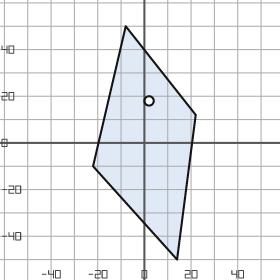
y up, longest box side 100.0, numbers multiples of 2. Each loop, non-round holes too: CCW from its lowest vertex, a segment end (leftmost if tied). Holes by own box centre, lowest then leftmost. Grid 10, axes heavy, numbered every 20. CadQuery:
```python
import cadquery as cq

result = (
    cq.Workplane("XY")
    .moveTo(14.0, -50.0)
    .lineTo(22.0, 12.0)
    .lineTo(-8.0, 50.0)
    .lineTo(-22.0, -10.0)
    .close()
    .moveTo(2.0, 18.0)
    .circle(2.0)
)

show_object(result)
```